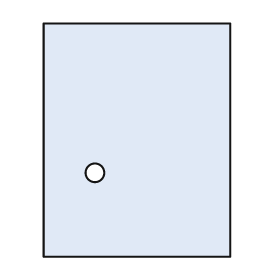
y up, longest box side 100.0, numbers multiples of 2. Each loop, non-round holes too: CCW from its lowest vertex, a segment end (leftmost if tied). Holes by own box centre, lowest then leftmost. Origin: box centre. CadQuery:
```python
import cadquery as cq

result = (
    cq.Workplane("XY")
    .moveTo(-40.0, -50.0)
    .lineTo(40.0, -50.0)
    .lineTo(40.0, 50.0)
    .lineTo(-40.0, 50.0)
    .close()
    .moveTo(-18.0, -14.0)
    .circle(4.0)
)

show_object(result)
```